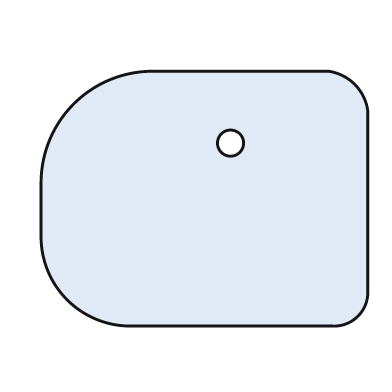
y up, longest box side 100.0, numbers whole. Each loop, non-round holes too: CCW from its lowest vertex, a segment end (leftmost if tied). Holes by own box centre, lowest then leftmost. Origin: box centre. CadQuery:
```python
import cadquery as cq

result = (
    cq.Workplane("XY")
    .moveTo(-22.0, -39.0)
    .lineTo(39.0, -39.0)
    .threePointArc((47.0, -36.0), (50.0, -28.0))
    .lineTo(50.0, 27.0)
    .threePointArc((46.0, 35.0), (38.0, 39.0))
    .lineTo(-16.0, 39.0)
    .threePointArc((-40.0, 29.0), (-50.0, 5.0))
    .lineTo(-50.0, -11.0)
    .threePointArc((-42.0, -31.0), (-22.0, -39.0))
    .close()
    .moveTo(8.0, 17.0)
    .circle(4.0)
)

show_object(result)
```